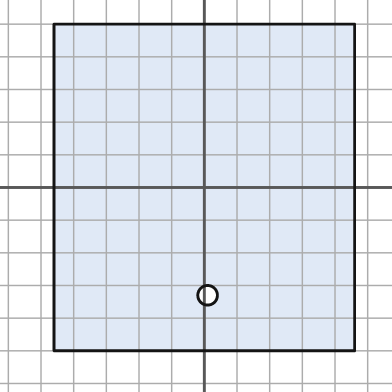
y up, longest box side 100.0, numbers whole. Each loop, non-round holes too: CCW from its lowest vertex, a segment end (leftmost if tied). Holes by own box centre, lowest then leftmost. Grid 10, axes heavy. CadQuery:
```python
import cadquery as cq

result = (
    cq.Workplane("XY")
    .moveTo(-46.0, -50.0)
    .lineTo(46.0, -50.0)
    .lineTo(46.0, 50.0)
    .lineTo(-46.0, 50.0)
    .close()
    .moveTo(1.0, -33.0)
    .circle(3.0)
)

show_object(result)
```